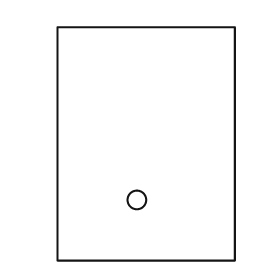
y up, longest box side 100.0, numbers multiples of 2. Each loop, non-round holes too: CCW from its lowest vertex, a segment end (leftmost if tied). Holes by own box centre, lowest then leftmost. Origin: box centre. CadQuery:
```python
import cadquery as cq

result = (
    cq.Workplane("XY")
    .moveTo(-38.0, -50.0)
    .lineTo(38.0, -50.0)
    .lineTo(38.0, 50.0)
    .lineTo(-38.0, 50.0)
    .close()
    .moveTo(-4.0, -24.0)
    .circle(4.0)
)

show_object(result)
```